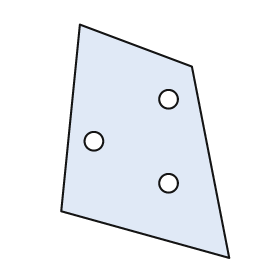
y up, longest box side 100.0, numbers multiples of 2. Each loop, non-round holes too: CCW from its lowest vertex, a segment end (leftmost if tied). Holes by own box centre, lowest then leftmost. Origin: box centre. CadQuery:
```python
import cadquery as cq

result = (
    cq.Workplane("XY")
    .moveTo(36.0, -50.0)
    .lineTo(20.0, 32.0)
    .lineTo(-28.0, 50.0)
    .lineTo(-36.0, -30.0)
    .close()
    .moveTo(10.0, -18.0)
    .circle(4.0)
    .moveTo(-22.0, 0.0)
    .circle(4.0)
    .moveTo(10.0, 18.0)
    .circle(4.0)
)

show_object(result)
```